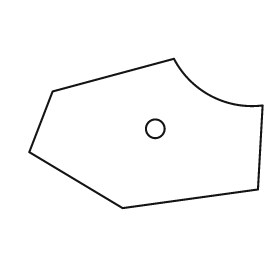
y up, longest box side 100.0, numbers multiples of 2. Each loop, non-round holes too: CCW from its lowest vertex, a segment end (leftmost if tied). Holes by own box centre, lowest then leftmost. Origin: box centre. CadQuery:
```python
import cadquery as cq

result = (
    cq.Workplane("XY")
    .moveTo(-10.0, -32.0)
    .lineTo(48.0, -24.0)
    .lineTo(50.0, 12.0)
    .threePointArc((28.0, 16.0), (12.0, 32.0))
    .lineTo(-40.0, 18.0)
    .lineTo(-50.0, -8.0)
    .close()
    .moveTo(4.0, 2.0)
    .circle(4.0)
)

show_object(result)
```